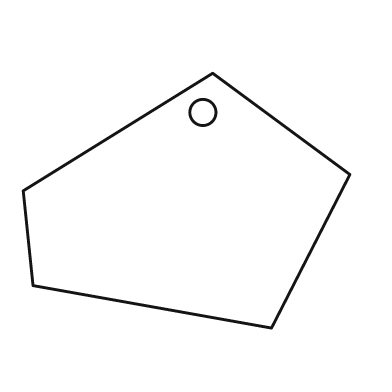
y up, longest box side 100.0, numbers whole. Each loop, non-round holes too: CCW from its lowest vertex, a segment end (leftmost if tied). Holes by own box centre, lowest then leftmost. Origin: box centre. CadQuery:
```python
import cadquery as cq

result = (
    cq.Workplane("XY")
    .moveTo(26.0, -39.0)
    .lineTo(50.0, 8.0)
    .lineTo(8.0, 39.0)
    .lineTo(-50.0, 3.0)
    .lineTo(-47.0, -26.0)
    .close()
    .moveTo(5.0, 27.0)
    .circle(4.0)
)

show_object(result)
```